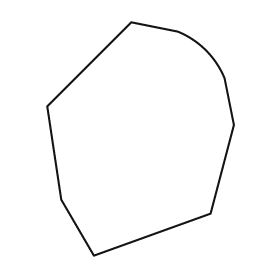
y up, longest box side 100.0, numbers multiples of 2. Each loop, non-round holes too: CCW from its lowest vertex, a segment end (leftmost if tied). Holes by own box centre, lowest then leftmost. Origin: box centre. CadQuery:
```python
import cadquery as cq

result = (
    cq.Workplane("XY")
    .moveTo(-20.0, -50.0)
    .lineTo(30.0, -32.0)
    .lineTo(40.0, 6.0)
    .lineTo(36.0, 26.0)
    .threePointArc((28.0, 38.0), (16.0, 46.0))
    .lineTo(-4.0, 50.0)
    .lineTo(-40.0, 14.0)
    .lineTo(-34.0, -26.0)
    .close()
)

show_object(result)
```